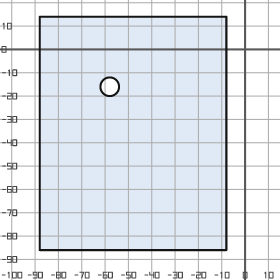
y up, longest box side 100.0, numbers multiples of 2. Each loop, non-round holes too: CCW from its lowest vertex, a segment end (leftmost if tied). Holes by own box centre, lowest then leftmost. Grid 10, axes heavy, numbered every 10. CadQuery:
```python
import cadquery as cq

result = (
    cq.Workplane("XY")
    .moveTo(-88.0, -86.0)
    .lineTo(-8.0, -86.0)
    .lineTo(-8.0, 14.0)
    .lineTo(-88.0, 14.0)
    .close()
    .moveTo(-58.0, -16.0)
    .circle(4.0)
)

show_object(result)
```